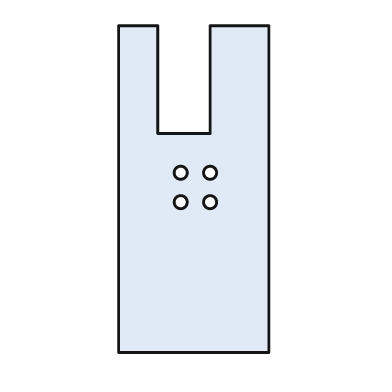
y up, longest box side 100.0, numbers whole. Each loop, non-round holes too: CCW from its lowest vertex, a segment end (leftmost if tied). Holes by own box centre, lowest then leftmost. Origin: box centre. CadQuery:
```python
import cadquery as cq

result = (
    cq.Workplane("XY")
    .moveTo(-23.0, -50.0)
    .lineTo(23.0, -50.0)
    .lineTo(23.0, 50.0)
    .lineTo(5.0, 50.0)
    .lineTo(5.0, 17.0)
    .lineTo(-11.0, 17.0)
    .lineTo(-11.0, 50.0)
    .lineTo(-23.0, 50.0)
    .close()
    .moveTo(-4.0, -4.0)
    .circle(2.0)
    .moveTo(5.0, -4.0)
    .circle(2.0)
    .moveTo(-4.0, 5.0)
    .circle(2.0)
    .moveTo(5.0, 5.0)
    .circle(2.0)
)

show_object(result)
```